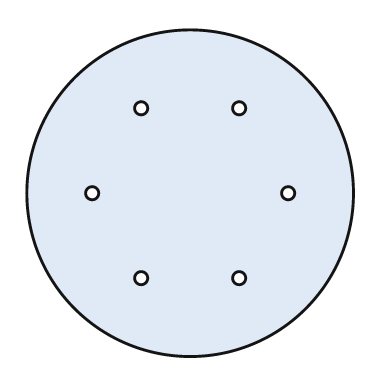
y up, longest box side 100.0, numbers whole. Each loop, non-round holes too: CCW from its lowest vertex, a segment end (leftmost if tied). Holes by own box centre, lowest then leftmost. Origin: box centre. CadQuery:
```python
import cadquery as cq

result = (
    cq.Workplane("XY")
    .moveTo(0.0, 0.0)
    .circle(50.0)
    .moveTo(-15.0, -26.0)
    .circle(2.0)
    .moveTo(15.0, -26.0)
    .circle(2.0)
    .moveTo(-30.0, 0.0)
    .circle(2.0)
    .moveTo(30.0, 0.0)
    .circle(2.0)
    .moveTo(-15.0, 26.0)
    .circle(2.0)
    .moveTo(15.0, 26.0)
    .circle(2.0)
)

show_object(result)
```